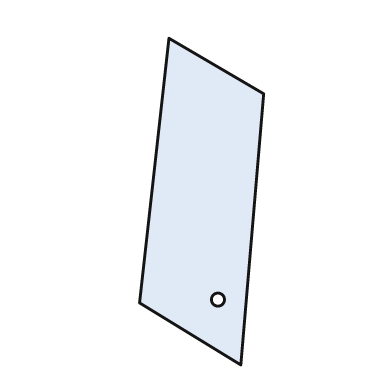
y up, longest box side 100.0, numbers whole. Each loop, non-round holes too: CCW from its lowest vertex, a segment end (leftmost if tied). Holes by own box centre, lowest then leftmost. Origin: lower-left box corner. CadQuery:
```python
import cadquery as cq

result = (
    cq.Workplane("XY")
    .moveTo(31.0, 0.0)
    .lineTo(38.0, 83.0)
    .lineTo(9.0, 100.0)
    .lineTo(0.0, 19.0)
    .close()
    .moveTo(24.0, 20.0)
    .circle(2.0)
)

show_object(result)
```